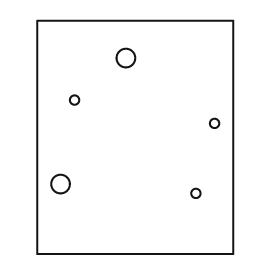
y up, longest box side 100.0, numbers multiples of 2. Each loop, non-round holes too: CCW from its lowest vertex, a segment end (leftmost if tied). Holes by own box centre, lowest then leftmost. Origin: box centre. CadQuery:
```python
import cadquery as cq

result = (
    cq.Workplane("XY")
    .moveTo(-42.0, -50.0)
    .lineTo(42.0, -50.0)
    .lineTo(42.0, 50.0)
    .lineTo(-42.0, 50.0)
    .close()
    .moveTo(26.0, -24.0)
    .circle(2.0)
    .moveTo(-32.0, -20.0)
    .circle(4.0)
    .moveTo(34.0, 6.0)
    .circle(2.0)
    .moveTo(-26.0, 16.0)
    .circle(2.0)
    .moveTo(-4.0, 34.0)
    .circle(4.0)
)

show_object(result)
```